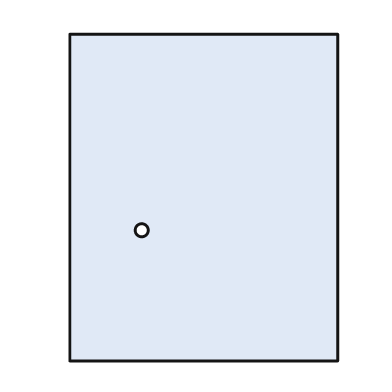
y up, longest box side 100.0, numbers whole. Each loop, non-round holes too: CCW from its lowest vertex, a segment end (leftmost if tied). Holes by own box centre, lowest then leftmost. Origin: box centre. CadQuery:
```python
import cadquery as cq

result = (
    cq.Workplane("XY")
    .moveTo(-41.0, -50.0)
    .lineTo(41.0, -50.0)
    .lineTo(41.0, 50.0)
    .lineTo(-41.0, 50.0)
    .close()
    .moveTo(-19.0, -10.0)
    .circle(2.0)
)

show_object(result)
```